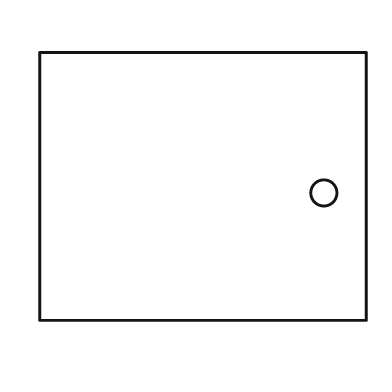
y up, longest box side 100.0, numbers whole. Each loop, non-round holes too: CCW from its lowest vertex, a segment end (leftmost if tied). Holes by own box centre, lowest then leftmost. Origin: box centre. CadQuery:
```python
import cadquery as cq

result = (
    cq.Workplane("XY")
    .moveTo(-50.0, -41.0)
    .lineTo(50.0, -41.0)
    .lineTo(50.0, 41.0)
    .lineTo(-50.0, 41.0)
    .close()
    .moveTo(37.0, -2.0)
    .circle(4.0)
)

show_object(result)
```